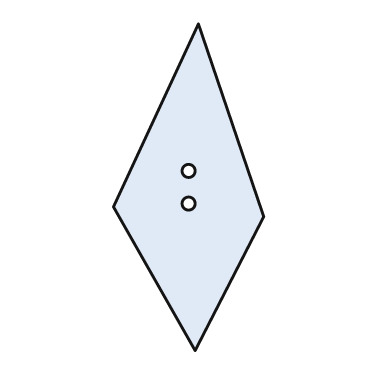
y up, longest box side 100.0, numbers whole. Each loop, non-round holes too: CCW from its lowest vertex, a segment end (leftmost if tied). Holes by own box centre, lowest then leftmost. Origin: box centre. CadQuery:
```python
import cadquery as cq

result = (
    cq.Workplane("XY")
    .moveTo(2.0, -50.0)
    .lineTo(23.0, -9.0)
    .lineTo(3.0, 50.0)
    .lineTo(-23.0, -6.0)
    .close()
    .moveTo(0.0, -5.0)
    .circle(2.0)
    .moveTo(0.0, 5.0)
    .circle(2.0)
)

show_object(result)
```